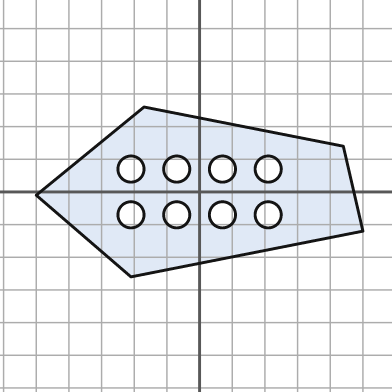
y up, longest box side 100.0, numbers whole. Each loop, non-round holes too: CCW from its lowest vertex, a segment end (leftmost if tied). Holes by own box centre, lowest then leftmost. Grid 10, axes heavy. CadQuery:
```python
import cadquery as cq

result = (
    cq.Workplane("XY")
    .moveTo(-21.0, -26.0)
    .lineTo(50.0, -12.0)
    .lineTo(44.0, 14.0)
    .lineTo(-17.0, 26.0)
    .lineTo(-50.0, -1.0)
    .close()
    .moveTo(-21.0, -7.0)
    .circle(4.0)
    .moveTo(-7.0, -7.0)
    .circle(4.0)
    .moveTo(7.0, -7.0)
    .circle(4.0)
    .moveTo(21.0, -7.0)
    .circle(4.0)
    .moveTo(-21.0, 7.0)
    .circle(4.0)
    .moveTo(-7.0, 7.0)
    .circle(4.0)
    .moveTo(7.0, 7.0)
    .circle(4.0)
    .moveTo(21.0, 7.0)
    .circle(4.0)
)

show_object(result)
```